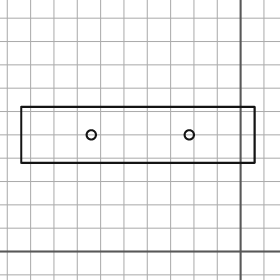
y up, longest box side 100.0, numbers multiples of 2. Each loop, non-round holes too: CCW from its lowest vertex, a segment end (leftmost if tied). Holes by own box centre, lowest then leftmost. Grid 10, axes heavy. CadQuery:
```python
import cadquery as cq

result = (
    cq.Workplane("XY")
    .moveTo(-94.0, 38.0)
    .lineTo(6.0, 38.0)
    .lineTo(6.0, 62.0)
    .lineTo(-94.0, 62.0)
    .close()
    .moveTo(-64.0, 50.0)
    .circle(2.0)
    .moveTo(-22.0, 50.0)
    .circle(2.0)
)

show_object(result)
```